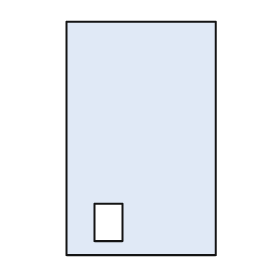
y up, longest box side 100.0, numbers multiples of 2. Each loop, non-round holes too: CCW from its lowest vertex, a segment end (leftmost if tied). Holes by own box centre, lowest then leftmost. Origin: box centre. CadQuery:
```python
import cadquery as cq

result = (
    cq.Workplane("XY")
    .moveTo(-32.0, -50.0)
    .lineTo(32.0, -50.0)
    .lineTo(32.0, 50.0)
    .lineTo(-32.0, 50.0)
    .close()
    .moveTo(-20.0, -44.0)
    .lineTo(-8.0, -44.0)
    .lineTo(-8.0, -28.0)
    .lineTo(-20.0, -28.0)
    .close()
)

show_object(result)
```